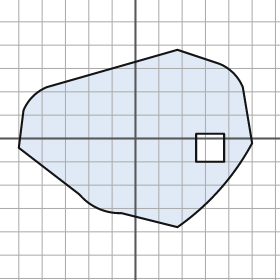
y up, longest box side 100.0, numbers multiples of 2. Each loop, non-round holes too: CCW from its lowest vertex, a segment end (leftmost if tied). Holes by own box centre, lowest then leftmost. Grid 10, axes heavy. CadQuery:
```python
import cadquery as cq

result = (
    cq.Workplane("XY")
    .moveTo(18.0, -38.0)
    .threePointArc((36.0, -22.0), (50.0, -2.0))
    .lineTo(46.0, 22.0)
    .threePointArc((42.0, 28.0), (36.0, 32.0))
    .lineTo(18.0, 38.0)
    .lineTo(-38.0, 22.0)
    .threePointArc((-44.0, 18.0), (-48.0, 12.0))
    .lineTo(-50.0, -4.0)
    .lineTo(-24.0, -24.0)
    .threePointArc((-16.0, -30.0), (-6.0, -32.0))
    .close()
    .moveTo(26.0, -10.0)
    .lineTo(38.0, -10.0)
    .lineTo(38.0, 2.0)
    .lineTo(26.0, 2.0)
    .close()
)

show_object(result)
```